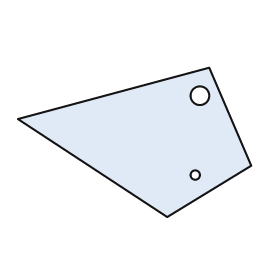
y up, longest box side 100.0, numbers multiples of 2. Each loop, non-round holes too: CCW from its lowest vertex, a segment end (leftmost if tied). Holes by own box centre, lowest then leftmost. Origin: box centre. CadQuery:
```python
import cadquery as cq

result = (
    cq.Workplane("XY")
    .moveTo(14.0, -32.0)
    .lineTo(50.0, -10.0)
    .lineTo(32.0, 32.0)
    .lineTo(-50.0, 10.0)
    .close()
    .moveTo(26.0, -14.0)
    .circle(2.0)
    .moveTo(28.0, 20.0)
    .circle(4.0)
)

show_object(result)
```